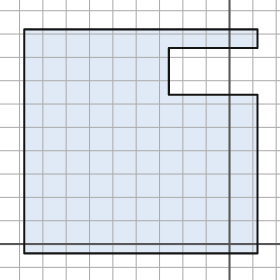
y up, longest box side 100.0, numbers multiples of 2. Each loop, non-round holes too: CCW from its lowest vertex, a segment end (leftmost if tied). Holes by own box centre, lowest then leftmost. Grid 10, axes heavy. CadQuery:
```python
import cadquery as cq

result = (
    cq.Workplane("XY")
    .moveTo(-88.0, -4.0)
    .lineTo(12.0, -4.0)
    .lineTo(12.0, 64.0)
    .lineTo(-26.0, 64.0)
    .lineTo(-26.0, 84.0)
    .lineTo(12.0, 84.0)
    .lineTo(12.0, 92.0)
    .lineTo(-88.0, 92.0)
    .close()
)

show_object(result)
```